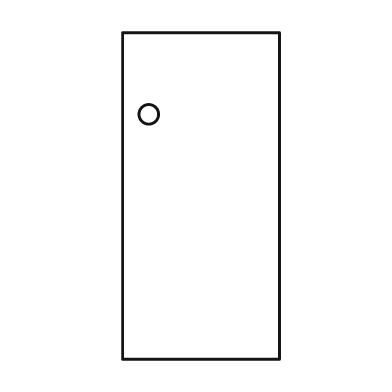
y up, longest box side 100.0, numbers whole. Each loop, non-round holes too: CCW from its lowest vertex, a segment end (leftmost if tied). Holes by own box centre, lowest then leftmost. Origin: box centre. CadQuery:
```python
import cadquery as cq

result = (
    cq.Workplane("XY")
    .moveTo(-24.0, -50.0)
    .lineTo(24.0, -50.0)
    .lineTo(24.0, 50.0)
    .lineTo(-24.0, 50.0)
    .close()
    .moveTo(-16.0, 25.0)
    .circle(3.0)
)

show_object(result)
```